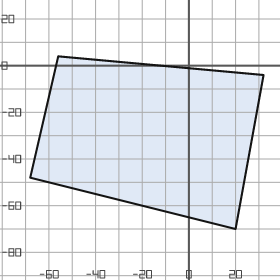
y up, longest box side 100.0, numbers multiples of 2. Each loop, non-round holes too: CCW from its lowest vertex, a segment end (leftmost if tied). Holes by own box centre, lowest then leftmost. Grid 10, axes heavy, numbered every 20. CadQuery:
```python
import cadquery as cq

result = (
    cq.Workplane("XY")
    .moveTo(20.0, -70.0)
    .lineTo(32.0, -4.0)
    .lineTo(-56.0, 4.0)
    .lineTo(-68.0, -48.0)
    .close()
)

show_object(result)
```